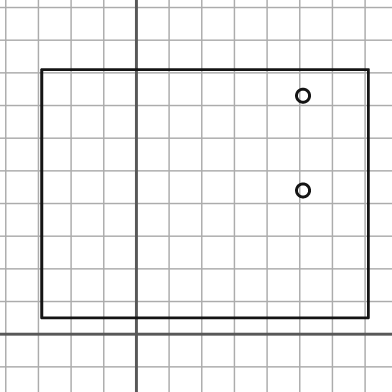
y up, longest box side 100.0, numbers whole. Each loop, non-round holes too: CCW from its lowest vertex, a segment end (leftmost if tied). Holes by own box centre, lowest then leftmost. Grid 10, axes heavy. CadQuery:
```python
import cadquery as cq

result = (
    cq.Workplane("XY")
    .moveTo(-29.0, 5.0)
    .lineTo(71.0, 5.0)
    .lineTo(71.0, 81.0)
    .lineTo(-29.0, 81.0)
    .close()
    .moveTo(51.0, 44.0)
    .circle(2.0)
    .moveTo(51.0, 73.0)
    .circle(2.0)
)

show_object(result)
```